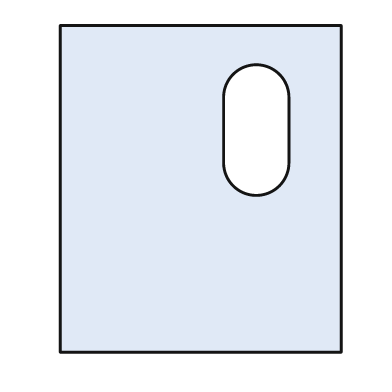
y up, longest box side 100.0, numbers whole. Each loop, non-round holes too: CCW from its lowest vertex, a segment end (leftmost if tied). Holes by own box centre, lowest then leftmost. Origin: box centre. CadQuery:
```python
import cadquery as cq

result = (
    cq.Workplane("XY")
    .moveTo(-43.0, -50.0)
    .lineTo(43.0, -50.0)
    .lineTo(43.0, 50.0)
    .lineTo(-43.0, 50.0)
    .close()
    .moveTo(7.0, 8.0)
    .threePointArc((17.0, -2.0), (27.0, 8.0))
    .lineTo(27.0, 28.0)
    .threePointArc((17.0, 38.0), (7.0, 28.0))
    .close()
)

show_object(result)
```